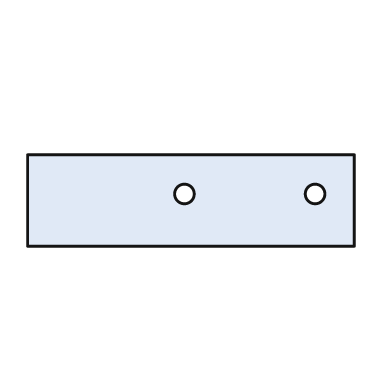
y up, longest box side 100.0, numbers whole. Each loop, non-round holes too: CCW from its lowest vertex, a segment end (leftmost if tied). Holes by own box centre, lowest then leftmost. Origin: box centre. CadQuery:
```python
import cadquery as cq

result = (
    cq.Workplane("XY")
    .moveTo(-50.0, -14.0)
    .lineTo(50.0, -14.0)
    .lineTo(50.0, 14.0)
    .lineTo(-50.0, 14.0)
    .close()
    .moveTo(-2.0, 2.0)
    .circle(3.0)
    .moveTo(38.0, 2.0)
    .circle(3.0)
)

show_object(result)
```